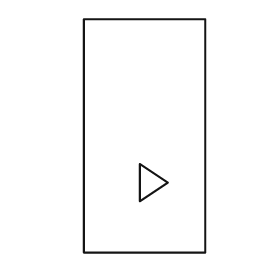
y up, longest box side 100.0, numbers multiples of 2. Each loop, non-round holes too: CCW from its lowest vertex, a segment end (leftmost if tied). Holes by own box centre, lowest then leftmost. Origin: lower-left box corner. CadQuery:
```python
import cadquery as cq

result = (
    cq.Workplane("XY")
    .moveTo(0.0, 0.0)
    .lineTo(52.0, 0.0)
    .lineTo(52.0, 100.0)
    .lineTo(0.0, 100.0)
    .close()
    .moveTo(24.0, 22.0)
    .lineTo(36.0, 30.0)
    .lineTo(24.0, 38.0)
    .close()
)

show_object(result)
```